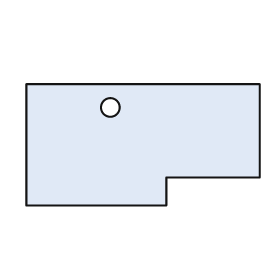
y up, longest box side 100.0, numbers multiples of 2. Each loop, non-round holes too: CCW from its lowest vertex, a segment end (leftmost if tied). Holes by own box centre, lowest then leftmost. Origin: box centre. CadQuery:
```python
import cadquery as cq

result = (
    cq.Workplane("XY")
    .moveTo(-50.0, -26.0)
    .lineTo(10.0, -26.0)
    .lineTo(10.0, -14.0)
    .lineTo(50.0, -14.0)
    .lineTo(50.0, 26.0)
    .lineTo(-50.0, 26.0)
    .close()
    .moveTo(-14.0, 16.0)
    .circle(4.0)
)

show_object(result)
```